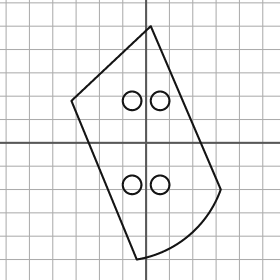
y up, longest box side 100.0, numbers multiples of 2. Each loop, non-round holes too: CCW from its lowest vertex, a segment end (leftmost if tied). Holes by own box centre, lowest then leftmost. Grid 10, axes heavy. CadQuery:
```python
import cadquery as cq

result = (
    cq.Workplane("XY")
    .moveTo(-4.0, -50.0)
    .threePointArc((18.0, -40.0), (32.0, -20.0))
    .lineTo(2.0, 50.0)
    .lineTo(-32.0, 18.0)
    .close()
    .moveTo(-6.0, -18.0)
    .circle(4.0)
    .moveTo(6.0, -18.0)
    .circle(4.0)
    .moveTo(-6.0, 18.0)
    .circle(4.0)
    .moveTo(6.0, 18.0)
    .circle(4.0)
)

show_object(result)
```